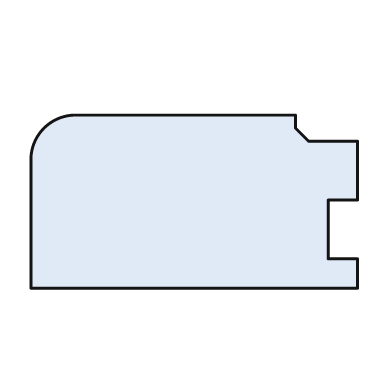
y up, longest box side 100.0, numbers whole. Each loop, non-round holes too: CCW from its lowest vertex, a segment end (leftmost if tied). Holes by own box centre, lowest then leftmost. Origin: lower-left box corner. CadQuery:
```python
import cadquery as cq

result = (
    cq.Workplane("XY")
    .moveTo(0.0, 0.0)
    .lineTo(100.0, 0.0)
    .lineTo(100.0, 9.0)
    .lineTo(91.0, 9.0)
    .lineTo(91.0, 27.0)
    .lineTo(100.0, 27.0)
    .lineTo(100.0, 45.0)
    .lineTo(85.0, 45.0)
    .lineTo(81.0, 49.0)
    .lineTo(81.0, 53.0)
    .lineTo(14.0, 53.0)
    .threePointArc((4.0, 49.0), (0.0, 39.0))
    .close()
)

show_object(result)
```